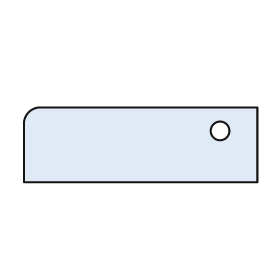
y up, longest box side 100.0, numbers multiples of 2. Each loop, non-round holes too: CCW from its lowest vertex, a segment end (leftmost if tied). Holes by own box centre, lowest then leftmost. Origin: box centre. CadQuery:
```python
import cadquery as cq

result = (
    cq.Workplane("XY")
    .moveTo(-50.0, -16.0)
    .lineTo(50.0, -16.0)
    .lineTo(50.0, 16.0)
    .lineTo(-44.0, 16.0)
    .threePointArc((-48.0, 14.0), (-50.0, 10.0))
    .close()
    .moveTo(34.0, 6.0)
    .circle(4.0)
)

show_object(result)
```